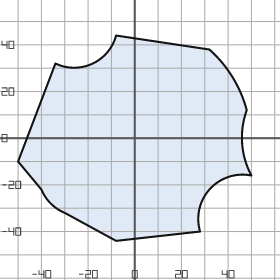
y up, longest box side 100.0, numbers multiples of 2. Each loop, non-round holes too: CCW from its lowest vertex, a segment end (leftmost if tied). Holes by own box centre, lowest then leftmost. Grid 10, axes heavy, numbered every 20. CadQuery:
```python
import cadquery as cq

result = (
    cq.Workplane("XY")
    .moveTo(-8.0, -44.0)
    .lineTo(28.0, -40.0)
    .threePointArc((32.0, -22.0), (50.0, -16.0))
    .threePointArc((46.0, -2.0), (48.0, 12.0))
    .threePointArc((42.0, 26.0), (32.0, 38.0))
    .lineTo(-8.0, 44.0)
    .threePointArc((-18.0, 32.0), (-34.0, 32.0))
    .lineTo(-50.0, -10.0)
    .lineTo(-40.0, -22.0)
    .threePointArc((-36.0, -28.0), (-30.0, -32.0))
    .close()
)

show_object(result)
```